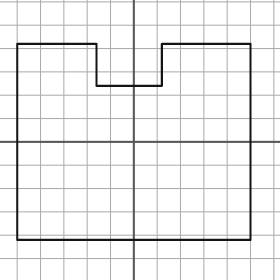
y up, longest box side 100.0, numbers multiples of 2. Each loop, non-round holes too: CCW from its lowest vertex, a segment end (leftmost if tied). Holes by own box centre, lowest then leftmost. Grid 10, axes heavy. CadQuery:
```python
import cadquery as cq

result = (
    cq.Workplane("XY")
    .moveTo(-50.0, -42.0)
    .lineTo(50.0, -42.0)
    .lineTo(50.0, 42.0)
    .lineTo(12.0, 42.0)
    .lineTo(12.0, 24.0)
    .lineTo(-16.0, 24.0)
    .lineTo(-16.0, 42.0)
    .lineTo(-50.0, 42.0)
    .close()
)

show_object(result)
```